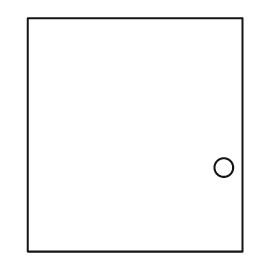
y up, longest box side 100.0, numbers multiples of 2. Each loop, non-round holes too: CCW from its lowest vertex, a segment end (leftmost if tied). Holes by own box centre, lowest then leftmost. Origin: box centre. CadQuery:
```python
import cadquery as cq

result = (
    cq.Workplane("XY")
    .moveTo(-46.0, -50.0)
    .lineTo(46.0, -50.0)
    .lineTo(46.0, 50.0)
    .lineTo(-46.0, 50.0)
    .close()
    .moveTo(38.0, -14.0)
    .circle(4.0)
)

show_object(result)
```